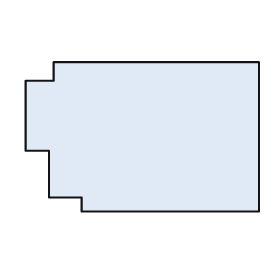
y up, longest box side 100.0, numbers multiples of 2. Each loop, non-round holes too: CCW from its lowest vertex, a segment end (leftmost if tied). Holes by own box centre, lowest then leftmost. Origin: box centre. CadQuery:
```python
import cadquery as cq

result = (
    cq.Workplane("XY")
    .moveTo(-26.0, -32.0)
    .lineTo(50.0, -32.0)
    .lineTo(50.0, 32.0)
    .lineTo(-38.0, 32.0)
    .lineTo(-38.0, 24.0)
    .lineTo(-50.0, 24.0)
    .lineTo(-50.0, -6.0)
    .lineTo(-40.0, -6.0)
    .lineTo(-40.0, -26.0)
    .lineTo(-26.0, -26.0)
    .close()
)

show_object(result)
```